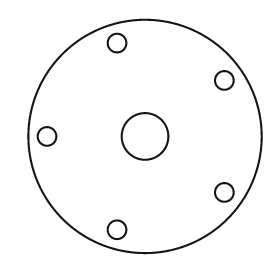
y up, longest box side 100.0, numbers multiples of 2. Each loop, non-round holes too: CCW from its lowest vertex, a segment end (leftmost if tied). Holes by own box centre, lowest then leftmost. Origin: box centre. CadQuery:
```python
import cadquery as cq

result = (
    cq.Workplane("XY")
    .moveTo(0.0, 0.0)
    .circle(50.0)
    .moveTo(-12.0, -40.0)
    .circle(4.0)
    .moveTo(34.0, -24.0)
    .circle(4.0)
    .moveTo(-42.0, 0.0)
    .circle(4.0)
    .moveTo(0.0, 0.0)
    .circle(10.0)
    .moveTo(34.0, 24.0)
    .circle(4.0)
    .moveTo(-12.0, 40.0)
    .circle(4.0)
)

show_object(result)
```